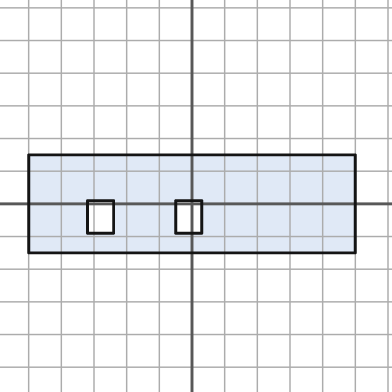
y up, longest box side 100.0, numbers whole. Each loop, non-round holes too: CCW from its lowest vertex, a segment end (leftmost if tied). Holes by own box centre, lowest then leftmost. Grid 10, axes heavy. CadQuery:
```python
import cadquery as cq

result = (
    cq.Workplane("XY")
    .moveTo(-50.0, -15.0)
    .lineTo(50.0, -15.0)
    .lineTo(50.0, 15.0)
    .lineTo(-50.0, 15.0)
    .close()
    .moveTo(-32.0, -9.0)
    .lineTo(-24.0, -9.0)
    .lineTo(-24.0, 1.0)
    .lineTo(-32.0, 1.0)
    .close()
    .moveTo(-5.0, -9.0)
    .lineTo(3.0, -9.0)
    .lineTo(3.0, 1.0)
    .lineTo(-5.0, 1.0)
    .close()
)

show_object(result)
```